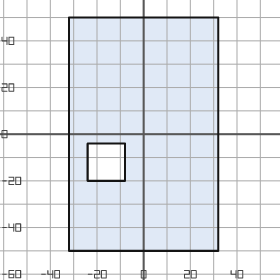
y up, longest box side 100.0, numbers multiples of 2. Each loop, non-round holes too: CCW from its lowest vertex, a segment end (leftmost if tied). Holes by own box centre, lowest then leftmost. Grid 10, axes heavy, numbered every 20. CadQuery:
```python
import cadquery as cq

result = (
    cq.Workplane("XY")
    .moveTo(-32.0, -50.0)
    .lineTo(32.0, -50.0)
    .lineTo(32.0, 50.0)
    .lineTo(-32.0, 50.0)
    .close()
    .moveTo(-24.0, -20.0)
    .lineTo(-8.0, -20.0)
    .lineTo(-8.0, -4.0)
    .lineTo(-24.0, -4.0)
    .close()
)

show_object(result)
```